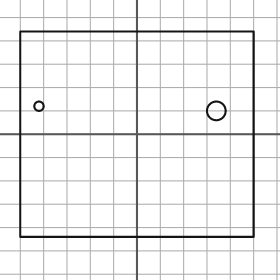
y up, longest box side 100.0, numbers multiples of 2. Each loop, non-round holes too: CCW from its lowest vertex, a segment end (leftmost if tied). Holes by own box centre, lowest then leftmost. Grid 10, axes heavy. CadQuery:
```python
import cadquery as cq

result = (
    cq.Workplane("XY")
    .moveTo(-50.0, -44.0)
    .lineTo(50.0, -44.0)
    .lineTo(50.0, 44.0)
    .lineTo(-50.0, 44.0)
    .close()
    .moveTo(34.0, 10.0)
    .circle(4.0)
    .moveTo(-42.0, 12.0)
    .circle(2.0)
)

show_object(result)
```